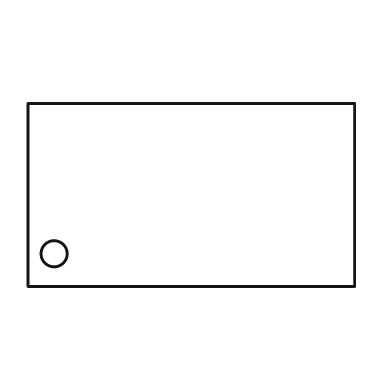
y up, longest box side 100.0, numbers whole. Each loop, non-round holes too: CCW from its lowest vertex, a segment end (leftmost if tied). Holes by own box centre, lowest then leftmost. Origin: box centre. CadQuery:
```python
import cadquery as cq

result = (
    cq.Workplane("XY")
    .moveTo(-50.0, -28.0)
    .lineTo(50.0, -28.0)
    .lineTo(50.0, 28.0)
    .lineTo(-50.0, 28.0)
    .close()
    .moveTo(-42.0, -18.0)
    .circle(4.0)
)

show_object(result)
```